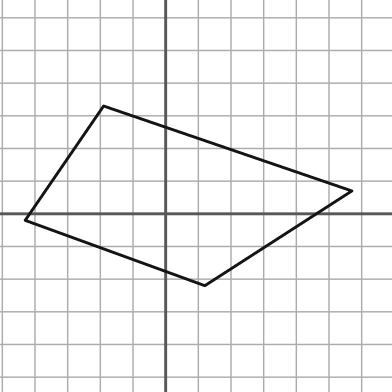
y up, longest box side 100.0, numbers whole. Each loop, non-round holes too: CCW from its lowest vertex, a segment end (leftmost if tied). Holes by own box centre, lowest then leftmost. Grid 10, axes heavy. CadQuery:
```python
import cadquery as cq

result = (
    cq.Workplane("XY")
    .moveTo(12.0, -22.0)
    .lineTo(57.0, 7.0)
    .lineTo(-19.0, 33.0)
    .lineTo(-43.0, -2.0)
    .close()
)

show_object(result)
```